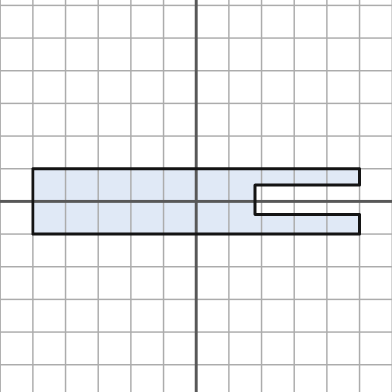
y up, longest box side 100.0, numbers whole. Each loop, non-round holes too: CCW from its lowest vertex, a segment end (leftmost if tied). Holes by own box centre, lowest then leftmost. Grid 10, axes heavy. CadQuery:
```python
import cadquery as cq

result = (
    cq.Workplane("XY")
    .moveTo(-50.0, -10.0)
    .lineTo(50.0, -10.0)
    .lineTo(50.0, -4.0)
    .lineTo(18.0, -4.0)
    .lineTo(18.0, 5.0)
    .lineTo(50.0, 5.0)
    .lineTo(50.0, 10.0)
    .lineTo(-50.0, 10.0)
    .close()
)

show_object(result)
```